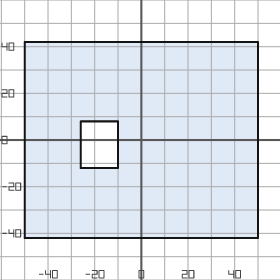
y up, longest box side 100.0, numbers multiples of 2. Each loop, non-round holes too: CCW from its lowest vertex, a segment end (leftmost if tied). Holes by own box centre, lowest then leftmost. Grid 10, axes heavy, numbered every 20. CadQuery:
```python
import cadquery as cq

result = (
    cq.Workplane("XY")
    .moveTo(-50.0, -42.0)
    .lineTo(50.0, -42.0)
    .lineTo(50.0, 42.0)
    .lineTo(-50.0, 42.0)
    .close()
    .moveTo(-26.0, -12.0)
    .lineTo(-10.0, -12.0)
    .lineTo(-10.0, 8.0)
    .lineTo(-26.0, 8.0)
    .close()
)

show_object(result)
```